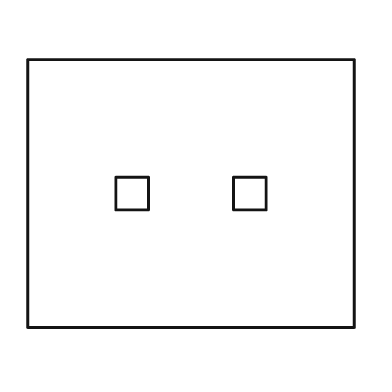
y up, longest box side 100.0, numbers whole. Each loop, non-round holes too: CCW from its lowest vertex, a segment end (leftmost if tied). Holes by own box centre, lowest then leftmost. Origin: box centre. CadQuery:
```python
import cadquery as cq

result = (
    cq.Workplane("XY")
    .moveTo(-50.0, -41.0)
    .lineTo(50.0, -41.0)
    .lineTo(50.0, 41.0)
    .lineTo(-50.0, 41.0)
    .close()
    .moveTo(-23.0, -5.0)
    .lineTo(-13.0, -5.0)
    .lineTo(-13.0, 5.0)
    .lineTo(-23.0, 5.0)
    .close()
    .moveTo(13.0, -5.0)
    .lineTo(23.0, -5.0)
    .lineTo(23.0, 5.0)
    .lineTo(13.0, 5.0)
    .close()
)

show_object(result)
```